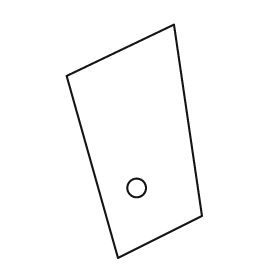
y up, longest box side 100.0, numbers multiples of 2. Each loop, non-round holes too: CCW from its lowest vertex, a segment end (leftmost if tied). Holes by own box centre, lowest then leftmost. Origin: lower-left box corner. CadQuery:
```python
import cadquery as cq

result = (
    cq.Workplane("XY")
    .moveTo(22.0, 0.0)
    .lineTo(58.0, 18.0)
    .lineTo(46.0, 100.0)
    .lineTo(0.0, 78.0)
    .close()
    .moveTo(30.0, 30.0)
    .circle(4.0)
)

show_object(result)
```